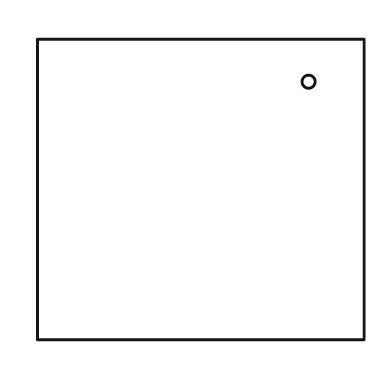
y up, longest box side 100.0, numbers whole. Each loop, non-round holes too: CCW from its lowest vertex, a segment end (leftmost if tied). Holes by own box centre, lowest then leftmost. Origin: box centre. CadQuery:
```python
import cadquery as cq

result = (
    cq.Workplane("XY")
    .moveTo(-50.0, -46.0)
    .lineTo(50.0, -46.0)
    .lineTo(50.0, 46.0)
    .lineTo(-50.0, 46.0)
    .close()
    .moveTo(33.0, 33.0)
    .circle(2.0)
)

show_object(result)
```